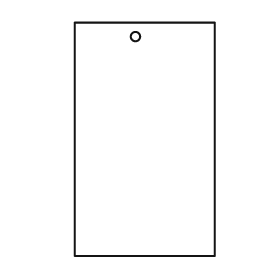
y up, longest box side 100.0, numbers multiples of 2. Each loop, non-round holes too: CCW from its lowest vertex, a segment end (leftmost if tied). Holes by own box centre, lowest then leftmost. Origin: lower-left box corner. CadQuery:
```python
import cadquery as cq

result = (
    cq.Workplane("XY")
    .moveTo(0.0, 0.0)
    .lineTo(60.0, 0.0)
    .lineTo(60.0, 100.0)
    .lineTo(0.0, 100.0)
    .close()
    .moveTo(26.0, 94.0)
    .circle(2.0)
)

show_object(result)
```